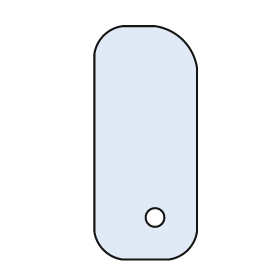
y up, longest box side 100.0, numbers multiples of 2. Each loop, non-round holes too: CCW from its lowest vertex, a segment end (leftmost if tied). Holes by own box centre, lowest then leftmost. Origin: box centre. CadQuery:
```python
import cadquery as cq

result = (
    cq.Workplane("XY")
    .moveTo(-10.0, -50.0)
    .lineTo(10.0, -50.0)
    .threePointArc((18.0, -46.0), (22.0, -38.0))
    .lineTo(22.0, 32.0)
    .threePointArc((16.0, 44.0), (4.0, 50.0))
    .lineTo(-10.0, 50.0)
    .threePointArc((-18.0, 46.0), (-22.0, 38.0))
    .lineTo(-22.0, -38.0)
    .threePointArc((-18.0, -46.0), (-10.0, -50.0))
    .close()
    .moveTo(4.0, -32.0)
    .circle(4.0)
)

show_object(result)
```